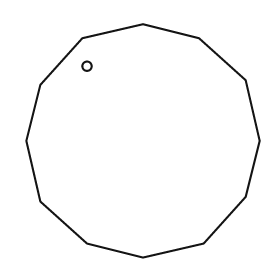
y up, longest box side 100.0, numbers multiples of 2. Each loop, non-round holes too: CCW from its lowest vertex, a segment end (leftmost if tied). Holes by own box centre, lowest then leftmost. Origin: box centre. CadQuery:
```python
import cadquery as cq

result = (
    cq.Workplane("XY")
    .moveTo(0.0, -50.0)
    .lineTo(26.0, -44.0)
    .lineTo(44.0, -24.0)
    .lineTo(50.0, 0.0)
    .lineTo(44.0, 26.0)
    .lineTo(24.0, 44.0)
    .lineTo(0.0, 50.0)
    .lineTo(-26.0, 44.0)
    .lineTo(-44.0, 24.0)
    .lineTo(-50.0, 0.0)
    .lineTo(-44.0, -26.0)
    .lineTo(-24.0, -44.0)
    .close()
    .moveTo(-24.0, 32.0)
    .circle(2.0)
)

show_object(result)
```